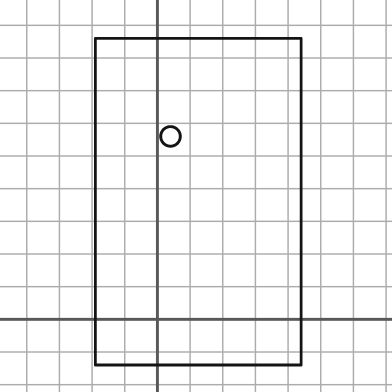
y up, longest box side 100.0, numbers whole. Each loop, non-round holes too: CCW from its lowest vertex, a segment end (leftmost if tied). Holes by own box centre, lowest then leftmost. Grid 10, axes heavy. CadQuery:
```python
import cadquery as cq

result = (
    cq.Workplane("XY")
    .moveTo(-19.0, -14.0)
    .lineTo(44.0, -14.0)
    .lineTo(44.0, 86.0)
    .lineTo(-19.0, 86.0)
    .close()
    .moveTo(4.0, 56.0)
    .circle(3.0)
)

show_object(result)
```